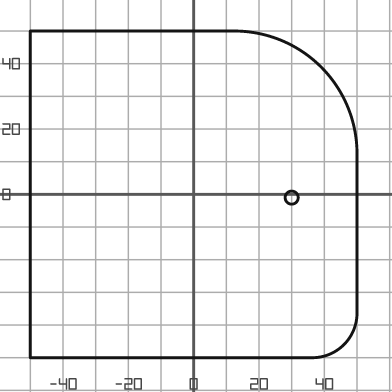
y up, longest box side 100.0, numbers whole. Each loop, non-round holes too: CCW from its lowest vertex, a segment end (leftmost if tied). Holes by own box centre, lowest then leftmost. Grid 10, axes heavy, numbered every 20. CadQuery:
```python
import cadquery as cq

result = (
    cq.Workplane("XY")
    .moveTo(-50.0, -50.0)
    .lineTo(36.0, -50.0)
    .threePointArc((46.0, -46.0), (50.0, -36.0))
    .lineTo(50.0, 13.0)
    .threePointArc((39.0, 39.0), (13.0, 50.0))
    .lineTo(-50.0, 50.0)
    .close()
    .moveTo(30.0, -1.0)
    .circle(2.0)
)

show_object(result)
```